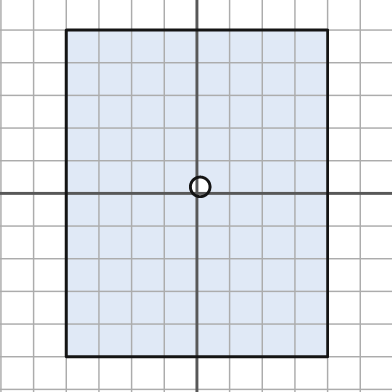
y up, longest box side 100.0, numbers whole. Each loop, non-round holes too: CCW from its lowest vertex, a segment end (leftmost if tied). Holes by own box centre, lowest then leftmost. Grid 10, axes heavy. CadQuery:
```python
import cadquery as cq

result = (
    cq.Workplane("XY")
    .moveTo(-40.0, -50.0)
    .lineTo(40.0, -50.0)
    .lineTo(40.0, 50.0)
    .lineTo(-40.0, 50.0)
    .close()
    .moveTo(1.0, 2.0)
    .circle(3.0)
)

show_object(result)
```